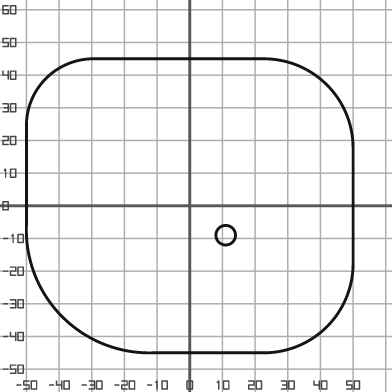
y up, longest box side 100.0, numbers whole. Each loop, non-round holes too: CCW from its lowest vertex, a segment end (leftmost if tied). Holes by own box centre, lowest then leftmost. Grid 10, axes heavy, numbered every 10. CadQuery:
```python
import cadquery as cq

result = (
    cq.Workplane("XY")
    .moveTo(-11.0, -45.0)
    .lineTo(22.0, -45.0)
    .threePointArc((42.0, -37.0), (50.0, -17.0))
    .lineTo(50.0, 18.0)
    .threePointArc((42.0, 37.0), (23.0, 45.0))
    .lineTo(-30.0, 45.0)
    .threePointArc((-44.0, 39.0), (-50.0, 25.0))
    .lineTo(-50.0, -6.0)
    .threePointArc((-39.0, -34.0), (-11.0, -45.0))
    .close()
    .moveTo(11.0, -9.0)
    .circle(3.0)
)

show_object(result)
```